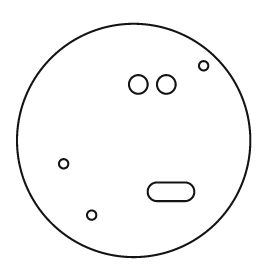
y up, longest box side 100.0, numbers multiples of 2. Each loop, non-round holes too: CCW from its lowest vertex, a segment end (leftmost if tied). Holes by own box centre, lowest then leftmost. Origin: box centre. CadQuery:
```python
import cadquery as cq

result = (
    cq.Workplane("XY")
    .moveTo(0.0, 0.0)
    .circle(50.0)
    .moveTo(-18.0, -32.0)
    .circle(2.0)
    .moveTo(10.0, -26.0)
    .lineTo(22.0, -26.0)
    .threePointArc((26.0, -22.0), (22.0, -18.0))
    .lineTo(10.0, -18.0)
    .threePointArc((6.0, -22.0), (10.0, -26.0))
    .close()
    .moveTo(-30.0, -10.0)
    .circle(2.0)
    .moveTo(2.0, 24.0)
    .circle(4.0)
    .moveTo(14.0, 24.0)
    .circle(4.0)
    .moveTo(30.0, 32.0)
    .circle(2.0)
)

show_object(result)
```